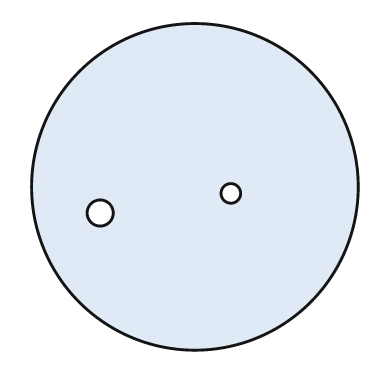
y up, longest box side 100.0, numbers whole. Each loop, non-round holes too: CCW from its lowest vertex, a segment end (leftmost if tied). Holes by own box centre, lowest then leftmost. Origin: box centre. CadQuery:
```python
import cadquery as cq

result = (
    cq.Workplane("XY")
    .moveTo(0.0, 0.0)
    .circle(50.0)
    .moveTo(-29.0, -8.0)
    .circle(4.0)
    .moveTo(11.0, -2.0)
    .circle(3.0)
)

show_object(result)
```